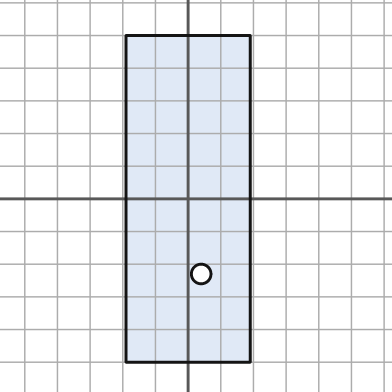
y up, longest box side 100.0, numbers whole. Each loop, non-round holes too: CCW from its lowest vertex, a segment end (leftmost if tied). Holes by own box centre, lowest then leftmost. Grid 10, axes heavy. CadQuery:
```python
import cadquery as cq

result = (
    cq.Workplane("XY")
    .moveTo(-19.0, -50.0)
    .lineTo(19.0, -50.0)
    .lineTo(19.0, 50.0)
    .lineTo(-19.0, 50.0)
    .close()
    .moveTo(4.0, -23.0)
    .circle(3.0)
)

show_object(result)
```